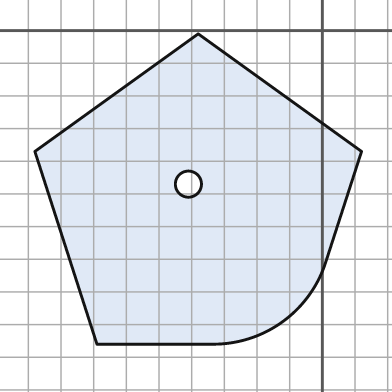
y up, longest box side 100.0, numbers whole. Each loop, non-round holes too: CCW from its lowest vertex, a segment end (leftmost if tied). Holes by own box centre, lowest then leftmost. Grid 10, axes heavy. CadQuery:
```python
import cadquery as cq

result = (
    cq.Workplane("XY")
    .moveTo(-69.0, -96.0)
    .lineTo(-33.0, -96.0)
    .threePointArc((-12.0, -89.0), (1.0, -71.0))
    .lineTo(12.0, -37.0)
    .lineTo(-38.0, -1.0)
    .lineTo(-88.0, -37.0)
    .close()
    .moveTo(-41.0, -47.0)
    .circle(4.0)
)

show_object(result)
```